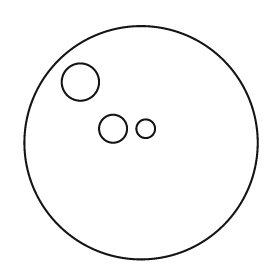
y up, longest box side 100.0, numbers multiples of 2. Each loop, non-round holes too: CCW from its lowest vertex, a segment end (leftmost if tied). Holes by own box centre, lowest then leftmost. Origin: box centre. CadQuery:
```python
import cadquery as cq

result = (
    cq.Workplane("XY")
    .moveTo(0.0, 0.0)
    .circle(50.0)
    .moveTo(-12.0, 6.0)
    .circle(6.0)
    .moveTo(2.0, 6.0)
    .circle(4.0)
    .moveTo(-26.0, 26.0)
    .circle(8.0)
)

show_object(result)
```